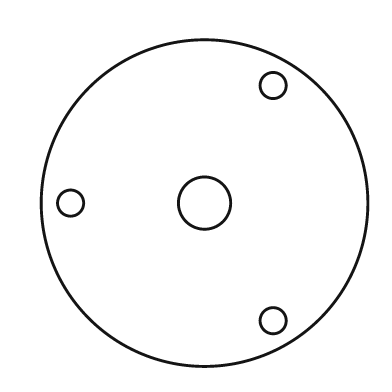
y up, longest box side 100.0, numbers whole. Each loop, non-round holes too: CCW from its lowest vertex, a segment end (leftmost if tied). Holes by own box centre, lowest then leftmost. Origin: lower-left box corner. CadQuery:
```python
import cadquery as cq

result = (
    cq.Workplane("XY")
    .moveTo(50.0, 50.0)
    .circle(50.0)
    .moveTo(71.0, 14.0)
    .circle(4.0)
    .moveTo(9.0, 50.0)
    .circle(4.0)
    .moveTo(50.0, 50.0)
    .circle(8.0)
    .moveTo(71.0, 86.0)
    .circle(4.0)
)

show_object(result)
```